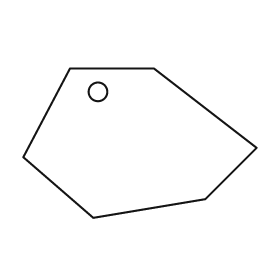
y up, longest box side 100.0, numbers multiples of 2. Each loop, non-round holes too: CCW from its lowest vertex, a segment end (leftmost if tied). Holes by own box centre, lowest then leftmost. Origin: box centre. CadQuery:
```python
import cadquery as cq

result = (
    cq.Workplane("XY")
    .moveTo(-20.0, -32.0)
    .lineTo(28.0, -24.0)
    .lineTo(50.0, -2.0)
    .lineTo(6.0, 32.0)
    .lineTo(-30.0, 32.0)
    .lineTo(-50.0, -6.0)
    .close()
    .moveTo(-18.0, 22.0)
    .circle(4.0)
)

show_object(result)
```